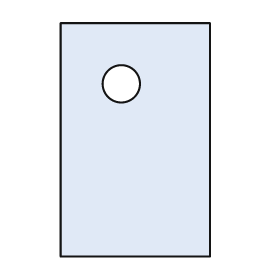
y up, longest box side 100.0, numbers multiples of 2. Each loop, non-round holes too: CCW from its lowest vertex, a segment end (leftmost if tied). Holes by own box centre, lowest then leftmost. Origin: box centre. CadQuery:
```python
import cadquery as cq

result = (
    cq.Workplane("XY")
    .moveTo(-32.0, -50.0)
    .lineTo(32.0, -50.0)
    .lineTo(32.0, 50.0)
    .lineTo(-32.0, 50.0)
    .close()
    .moveTo(-6.0, 24.0)
    .circle(8.0)
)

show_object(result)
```